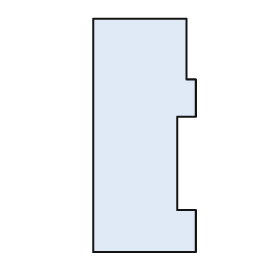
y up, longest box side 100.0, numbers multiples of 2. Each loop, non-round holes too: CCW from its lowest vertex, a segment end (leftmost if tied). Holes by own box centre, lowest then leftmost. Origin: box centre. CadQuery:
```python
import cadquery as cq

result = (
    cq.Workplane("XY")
    .moveTo(-22.0, -50.0)
    .lineTo(22.0, -50.0)
    .lineTo(22.0, -32.0)
    .lineTo(14.0, -32.0)
    .lineTo(14.0, 8.0)
    .lineTo(22.0, 8.0)
    .lineTo(22.0, 24.0)
    .lineTo(18.0, 24.0)
    .lineTo(18.0, 50.0)
    .lineTo(-22.0, 50.0)
    .close()
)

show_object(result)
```